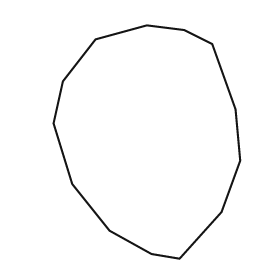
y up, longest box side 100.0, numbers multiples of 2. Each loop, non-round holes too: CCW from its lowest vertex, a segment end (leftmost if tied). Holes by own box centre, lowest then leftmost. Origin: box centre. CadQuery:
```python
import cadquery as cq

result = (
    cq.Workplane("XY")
    .moveTo(14.0, -50.0)
    .lineTo(32.0, -30.0)
    .lineTo(40.0, -8.0)
    .lineTo(38.0, 14.0)
    .lineTo(28.0, 42.0)
    .lineTo(16.0, 48.0)
    .lineTo(0.0, 50.0)
    .lineTo(-22.0, 44.0)
    .lineTo(-36.0, 26.0)
    .lineTo(-40.0, 8.0)
    .lineTo(-32.0, -18.0)
    .lineTo(-16.0, -38.0)
    .lineTo(2.0, -48.0)
    .close()
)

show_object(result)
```